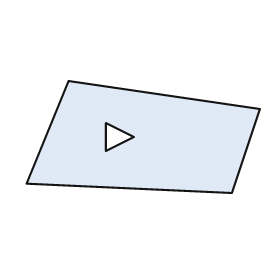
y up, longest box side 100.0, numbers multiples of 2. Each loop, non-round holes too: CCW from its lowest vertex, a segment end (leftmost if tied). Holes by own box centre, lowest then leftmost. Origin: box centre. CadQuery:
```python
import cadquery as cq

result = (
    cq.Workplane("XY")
    .moveTo(38.0, -24.0)
    .lineTo(50.0, 12.0)
    .lineTo(-32.0, 24.0)
    .lineTo(-50.0, -20.0)
    .close()
    .moveTo(-16.0, -6.0)
    .lineTo(-4.0, 0.0)
    .lineTo(-16.0, 6.0)
    .close()
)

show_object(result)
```